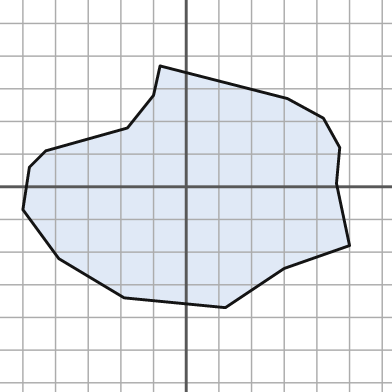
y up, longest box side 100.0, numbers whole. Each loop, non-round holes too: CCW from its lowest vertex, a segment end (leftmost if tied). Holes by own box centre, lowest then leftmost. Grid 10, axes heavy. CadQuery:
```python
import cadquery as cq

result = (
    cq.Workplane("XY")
    .moveTo(12.0, -37.0)
    .lineTo(30.0, -25.0)
    .lineTo(50.0, -18.0)
    .lineTo(46.0, 1.0)
    .lineTo(47.0, 12.0)
    .lineTo(42.0, 21.0)
    .lineTo(31.0, 27.0)
    .lineTo(-8.0, 37.0)
    .lineTo(-10.0, 28.0)
    .lineTo(-18.0, 18.0)
    .lineTo(-43.0, 11.0)
    .lineTo(-48.0, 6.0)
    .lineTo(-50.0, -7.0)
    .lineTo(-39.0, -22.0)
    .lineTo(-19.0, -34.0)
    .close()
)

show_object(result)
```